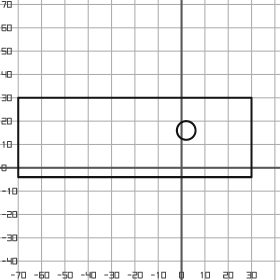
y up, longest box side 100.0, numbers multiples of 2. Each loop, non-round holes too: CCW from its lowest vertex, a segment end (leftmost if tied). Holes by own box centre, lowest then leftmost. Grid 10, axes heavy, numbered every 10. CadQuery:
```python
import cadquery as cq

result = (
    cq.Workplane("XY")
    .moveTo(-70.0, -4.0)
    .lineTo(30.0, -4.0)
    .lineTo(30.0, 30.0)
    .lineTo(-70.0, 30.0)
    .close()
    .moveTo(2.0, 16.0)
    .circle(4.0)
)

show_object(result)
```